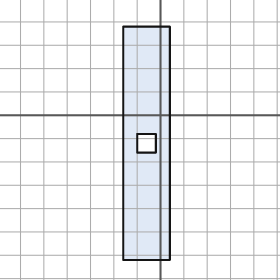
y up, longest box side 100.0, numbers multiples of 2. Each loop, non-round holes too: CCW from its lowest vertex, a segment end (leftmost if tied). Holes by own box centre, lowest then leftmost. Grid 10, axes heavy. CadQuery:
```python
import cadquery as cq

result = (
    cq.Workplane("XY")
    .moveTo(-16.0, -62.0)
    .lineTo(4.0, -62.0)
    .lineTo(4.0, 38.0)
    .lineTo(-16.0, 38.0)
    .close()
    .moveTo(-10.0, -16.0)
    .lineTo(-2.0, -16.0)
    .lineTo(-2.0, -8.0)
    .lineTo(-10.0, -8.0)
    .close()
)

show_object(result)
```